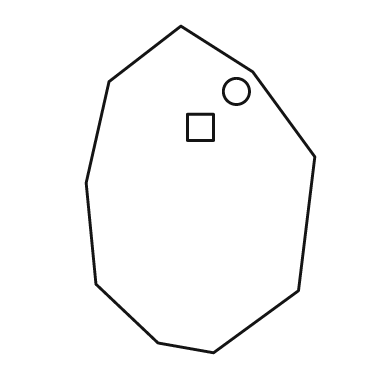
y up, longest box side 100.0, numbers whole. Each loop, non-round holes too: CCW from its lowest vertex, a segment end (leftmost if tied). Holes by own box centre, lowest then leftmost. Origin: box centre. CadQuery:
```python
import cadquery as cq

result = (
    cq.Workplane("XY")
    .moveTo(4.0, -50.0)
    .lineTo(30.0, -31.0)
    .lineTo(35.0, 10.0)
    .lineTo(16.0, 36.0)
    .lineTo(-6.0, 50.0)
    .lineTo(-28.0, 33.0)
    .lineTo(-35.0, 2.0)
    .lineTo(-32.0, -29.0)
    .lineTo(-13.0, -47.0)
    .close()
    .moveTo(-4.0, 15.0)
    .lineTo(4.0, 15.0)
    .lineTo(4.0, 23.0)
    .lineTo(-4.0, 23.0)
    .close()
    .moveTo(11.0, 30.0)
    .circle(4.0)
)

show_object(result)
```